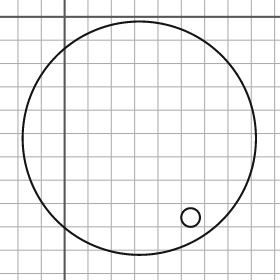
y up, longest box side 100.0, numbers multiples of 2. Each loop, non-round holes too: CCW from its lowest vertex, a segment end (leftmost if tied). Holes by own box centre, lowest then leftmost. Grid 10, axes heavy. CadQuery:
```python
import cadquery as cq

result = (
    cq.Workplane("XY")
    .moveTo(32.0, -52.0)
    .circle(50.0)
    .moveTo(54.0, -86.0)
    .circle(4.0)
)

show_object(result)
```